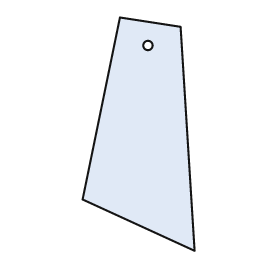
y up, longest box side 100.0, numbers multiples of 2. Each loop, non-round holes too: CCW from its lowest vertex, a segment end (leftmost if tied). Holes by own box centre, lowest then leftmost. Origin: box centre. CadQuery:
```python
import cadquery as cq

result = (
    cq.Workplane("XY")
    .moveTo(24.0, -50.0)
    .lineTo(18.0, 46.0)
    .lineTo(-8.0, 50.0)
    .lineTo(-24.0, -28.0)
    .close()
    .moveTo(4.0, 38.0)
    .circle(2.0)
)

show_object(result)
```